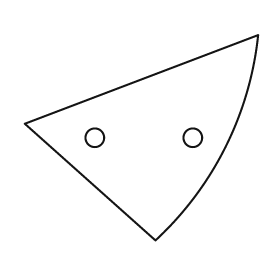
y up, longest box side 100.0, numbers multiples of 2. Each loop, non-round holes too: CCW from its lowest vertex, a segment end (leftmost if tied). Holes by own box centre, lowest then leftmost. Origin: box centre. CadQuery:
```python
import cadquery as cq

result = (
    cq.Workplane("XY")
    .moveTo(6.0, -44.0)
    .threePointArc((36.0, -4.0), (50.0, 44.0))
    .lineTo(-50.0, 6.0)
    .close()
    .moveTo(-20.0, 0.0)
    .circle(4.0)
    .moveTo(22.0, 0.0)
    .circle(4.0)
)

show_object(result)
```